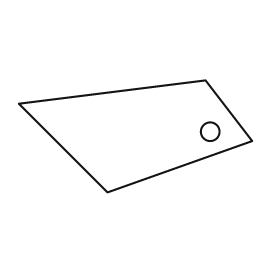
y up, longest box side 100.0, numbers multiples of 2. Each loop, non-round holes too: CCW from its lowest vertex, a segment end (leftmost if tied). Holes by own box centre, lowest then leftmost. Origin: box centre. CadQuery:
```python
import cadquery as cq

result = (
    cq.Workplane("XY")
    .moveTo(-12.0, -24.0)
    .lineTo(50.0, -2.0)
    .lineTo(30.0, 24.0)
    .lineTo(-50.0, 14.0)
    .close()
    .moveTo(32.0, 2.0)
    .circle(4.0)
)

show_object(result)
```